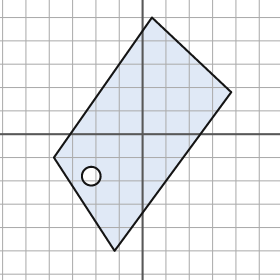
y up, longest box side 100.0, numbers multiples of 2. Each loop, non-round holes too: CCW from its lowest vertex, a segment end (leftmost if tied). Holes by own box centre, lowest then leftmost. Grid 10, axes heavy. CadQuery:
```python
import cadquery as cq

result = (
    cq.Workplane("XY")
    .moveTo(-12.0, -50.0)
    .lineTo(38.0, 18.0)
    .lineTo(4.0, 50.0)
    .lineTo(-38.0, -10.0)
    .close()
    .moveTo(-22.0, -18.0)
    .circle(4.0)
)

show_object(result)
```